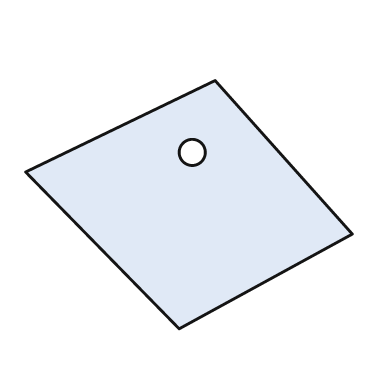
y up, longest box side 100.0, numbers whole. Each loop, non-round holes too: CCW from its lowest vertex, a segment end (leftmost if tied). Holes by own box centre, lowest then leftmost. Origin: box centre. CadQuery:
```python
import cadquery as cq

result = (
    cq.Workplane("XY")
    .moveTo(-3.0, -38.0)
    .lineTo(50.0, -9.0)
    .lineTo(8.0, 38.0)
    .lineTo(-50.0, 10.0)
    .close()
    .moveTo(1.0, 16.0)
    .circle(4.0)
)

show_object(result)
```